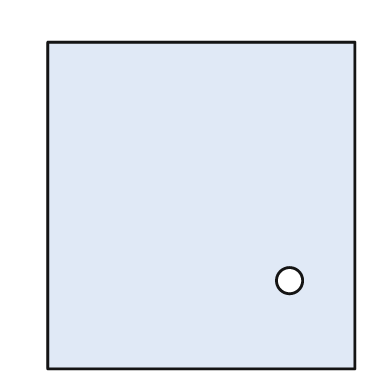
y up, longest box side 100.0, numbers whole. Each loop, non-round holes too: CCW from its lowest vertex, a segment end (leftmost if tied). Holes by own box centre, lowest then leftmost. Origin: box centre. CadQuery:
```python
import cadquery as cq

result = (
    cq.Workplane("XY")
    .moveTo(-47.0, -50.0)
    .lineTo(47.0, -50.0)
    .lineTo(47.0, 50.0)
    .lineTo(-47.0, 50.0)
    .close()
    .moveTo(27.0, -23.0)
    .circle(4.0)
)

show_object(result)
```